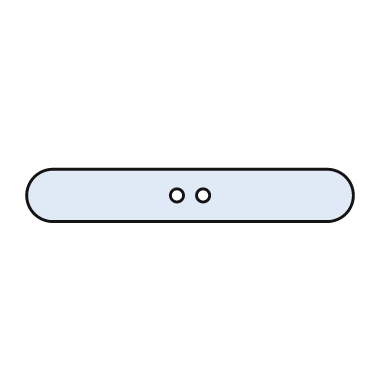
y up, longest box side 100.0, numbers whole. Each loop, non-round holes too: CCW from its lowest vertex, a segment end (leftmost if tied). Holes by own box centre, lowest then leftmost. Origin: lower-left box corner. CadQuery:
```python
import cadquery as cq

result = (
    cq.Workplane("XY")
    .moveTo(8.0, 0.0)
    .lineTo(92.0, 0.0)
    .threePointArc((100.0, 8.0), (92.0, 16.0))
    .lineTo(8.0, 16.0)
    .threePointArc((0.0, 8.0), (8.0, 0.0))
    .close()
    .moveTo(46.0, 8.0)
    .circle(2.0)
    .moveTo(54.0, 8.0)
    .circle(2.0)
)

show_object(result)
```